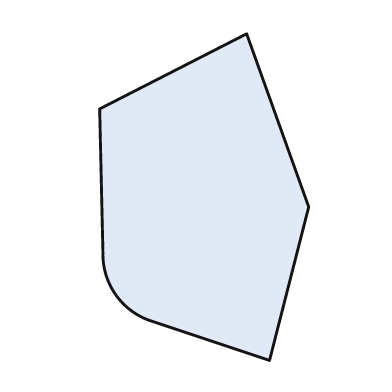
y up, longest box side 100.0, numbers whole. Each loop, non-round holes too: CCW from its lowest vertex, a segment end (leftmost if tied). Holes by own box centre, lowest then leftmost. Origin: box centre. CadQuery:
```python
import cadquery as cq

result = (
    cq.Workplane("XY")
    .moveTo(20.0, -50.0)
    .lineTo(32.0, -3.0)
    .lineTo(13.0, 50.0)
    .lineTo(-32.0, 27.0)
    .lineTo(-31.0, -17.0)
    .threePointArc((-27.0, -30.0), (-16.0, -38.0))
    .close()
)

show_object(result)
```